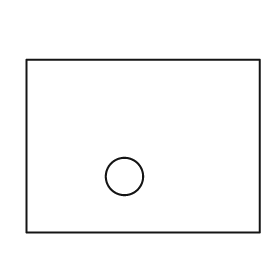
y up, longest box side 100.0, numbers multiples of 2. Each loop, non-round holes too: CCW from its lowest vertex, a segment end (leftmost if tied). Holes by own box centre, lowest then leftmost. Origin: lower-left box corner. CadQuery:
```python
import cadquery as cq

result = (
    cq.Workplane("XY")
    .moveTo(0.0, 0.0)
    .lineTo(100.0, 0.0)
    .lineTo(100.0, 74.0)
    .lineTo(0.0, 74.0)
    .close()
    .moveTo(42.0, 24.0)
    .circle(8.0)
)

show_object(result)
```